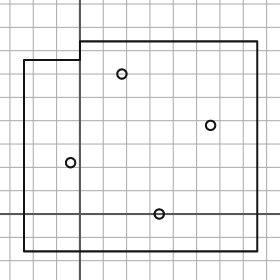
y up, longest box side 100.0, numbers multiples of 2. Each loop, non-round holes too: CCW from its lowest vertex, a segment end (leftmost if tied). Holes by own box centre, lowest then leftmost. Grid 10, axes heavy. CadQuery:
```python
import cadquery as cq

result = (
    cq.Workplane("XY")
    .moveTo(-24.0, -16.0)
    .lineTo(76.0, -16.0)
    .lineTo(76.0, 74.0)
    .lineTo(0.0, 74.0)
    .lineTo(0.0, 66.0)
    .lineTo(-24.0, 66.0)
    .close()
    .moveTo(34.0, 0.0)
    .circle(2.0)
    .moveTo(-4.0, 22.0)
    .circle(2.0)
    .moveTo(56.0, 38.0)
    .circle(2.0)
    .moveTo(18.0, 60.0)
    .circle(2.0)
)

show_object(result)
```